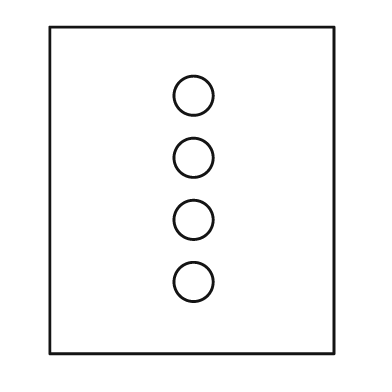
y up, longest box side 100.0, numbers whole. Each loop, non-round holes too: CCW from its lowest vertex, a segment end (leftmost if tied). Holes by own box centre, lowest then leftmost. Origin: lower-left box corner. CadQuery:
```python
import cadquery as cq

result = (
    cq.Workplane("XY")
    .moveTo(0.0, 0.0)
    .lineTo(87.0, 0.0)
    .lineTo(87.0, 100.0)
    .lineTo(0.0, 100.0)
    .close()
    .moveTo(44.0, 22.0)
    .circle(6.0)
    .moveTo(44.0, 41.0)
    .circle(6.0)
    .moveTo(44.0, 60.0)
    .circle(6.0)
    .moveTo(44.0, 79.0)
    .circle(6.0)
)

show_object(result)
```